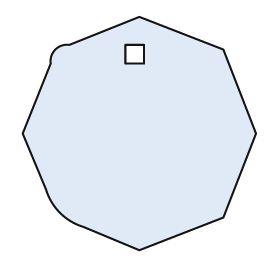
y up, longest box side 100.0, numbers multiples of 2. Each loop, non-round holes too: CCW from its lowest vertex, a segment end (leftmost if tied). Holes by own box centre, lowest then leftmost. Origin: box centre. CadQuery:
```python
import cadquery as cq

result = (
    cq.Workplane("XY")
    .moveTo(0.0, -50.0)
    .lineTo(36.0, -36.0)
    .lineTo(50.0, 0.0)
    .lineTo(36.0, 36.0)
    .lineTo(0.0, 50.0)
    .lineTo(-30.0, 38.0)
    .threePointArc((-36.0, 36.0), (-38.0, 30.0))
    .lineTo(-50.0, 0.0)
    .lineTo(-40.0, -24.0)
    .threePointArc((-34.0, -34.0), (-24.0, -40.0))
    .close()
    .moveTo(-6.0, 30.0)
    .lineTo(2.0, 30.0)
    .lineTo(2.0, 38.0)
    .lineTo(-6.0, 38.0)
    .close()
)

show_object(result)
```